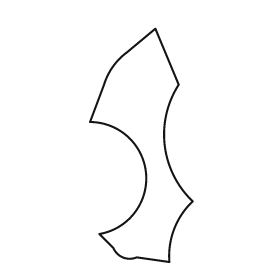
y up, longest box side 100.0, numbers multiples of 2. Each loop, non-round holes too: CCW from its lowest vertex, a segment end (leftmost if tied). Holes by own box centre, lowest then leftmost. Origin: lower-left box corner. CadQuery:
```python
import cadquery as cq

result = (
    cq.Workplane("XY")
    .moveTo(34.0, 0.0)
    .threePointArc((36.0, 14.0), (44.0, 26.0))
    .threePointArc((32.0, 50.0), (38.0, 76.0))
    .lineTo(28.0, 100.0)
    .lineTo(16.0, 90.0)
    .threePointArc((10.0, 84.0), (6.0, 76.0))
    .lineTo(0.0, 60.0)
    .threePointArc((24.0, 38.0), (4.0, 12.0))
    .lineTo(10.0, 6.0)
    .threePointArc((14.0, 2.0), (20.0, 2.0))
    .close()
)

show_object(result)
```